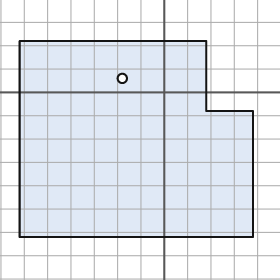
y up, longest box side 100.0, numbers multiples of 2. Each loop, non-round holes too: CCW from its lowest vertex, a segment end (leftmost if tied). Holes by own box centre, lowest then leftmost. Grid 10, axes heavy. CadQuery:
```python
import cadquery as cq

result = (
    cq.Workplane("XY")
    .moveTo(-62.0, -62.0)
    .lineTo(38.0, -62.0)
    .lineTo(38.0, -8.0)
    .lineTo(18.0, -8.0)
    .lineTo(18.0, 22.0)
    .lineTo(-62.0, 22.0)
    .close()
    .moveTo(-18.0, 6.0)
    .circle(2.0)
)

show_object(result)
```